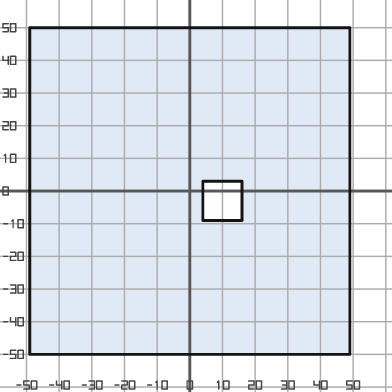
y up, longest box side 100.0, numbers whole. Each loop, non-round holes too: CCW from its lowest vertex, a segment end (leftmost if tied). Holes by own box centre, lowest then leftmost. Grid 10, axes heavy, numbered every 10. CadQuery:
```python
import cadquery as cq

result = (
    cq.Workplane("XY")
    .moveTo(-49.0, -50.0)
    .lineTo(49.0, -50.0)
    .lineTo(49.0, 50.0)
    .lineTo(-49.0, 50.0)
    .close()
    .moveTo(4.0, -9.0)
    .lineTo(16.0, -9.0)
    .lineTo(16.0, 3.0)
    .lineTo(4.0, 3.0)
    .close()
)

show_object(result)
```